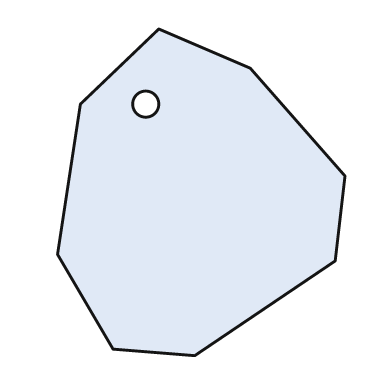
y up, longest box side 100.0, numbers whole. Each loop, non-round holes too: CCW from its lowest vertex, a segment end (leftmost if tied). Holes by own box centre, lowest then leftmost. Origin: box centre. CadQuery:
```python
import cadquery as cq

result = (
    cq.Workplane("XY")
    .moveTo(-2.0, -50.0)
    .lineTo(41.0, -21.0)
    .lineTo(44.0, 5.0)
    .lineTo(15.0, 38.0)
    .lineTo(-13.0, 50.0)
    .lineTo(-37.0, 27.0)
    .lineTo(-44.0, -19.0)
    .lineTo(-27.0, -48.0)
    .close()
    .moveTo(-17.0, 27.0)
    .circle(4.0)
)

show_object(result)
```